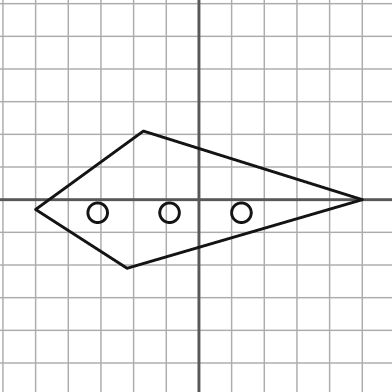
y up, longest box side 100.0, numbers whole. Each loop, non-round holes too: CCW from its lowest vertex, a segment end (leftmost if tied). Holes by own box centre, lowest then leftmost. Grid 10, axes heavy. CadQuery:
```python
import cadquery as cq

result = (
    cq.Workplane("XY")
    .moveTo(-22.0, -21.0)
    .lineTo(50.0, 0.0)
    .lineTo(-17.0, 21.0)
    .lineTo(-50.0, -3.0)
    .close()
    .moveTo(-31.0, -4.0)
    .circle(3.0)
    .moveTo(-9.0, -4.0)
    .circle(3.0)
    .moveTo(13.0, -4.0)
    .circle(3.0)
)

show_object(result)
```